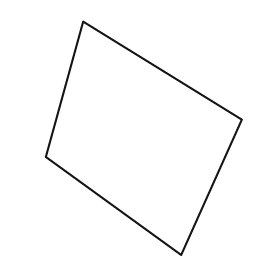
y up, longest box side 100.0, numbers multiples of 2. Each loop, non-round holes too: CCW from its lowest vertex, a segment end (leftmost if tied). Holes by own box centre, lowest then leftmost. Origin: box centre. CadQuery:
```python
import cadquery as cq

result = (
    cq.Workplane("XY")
    .moveTo(16.0, -50.0)
    .lineTo(42.0, 8.0)
    .lineTo(-26.0, 50.0)
    .lineTo(-42.0, -8.0)
    .close()
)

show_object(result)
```